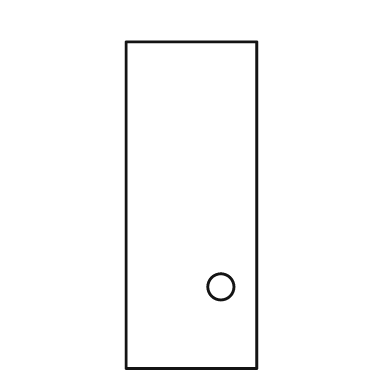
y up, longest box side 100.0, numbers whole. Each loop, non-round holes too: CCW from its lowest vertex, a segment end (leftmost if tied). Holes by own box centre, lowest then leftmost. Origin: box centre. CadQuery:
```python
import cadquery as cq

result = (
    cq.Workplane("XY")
    .moveTo(-20.0, -50.0)
    .lineTo(20.0, -50.0)
    .lineTo(20.0, 50.0)
    .lineTo(-20.0, 50.0)
    .close()
    .moveTo(9.0, -25.0)
    .circle(4.0)
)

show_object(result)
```